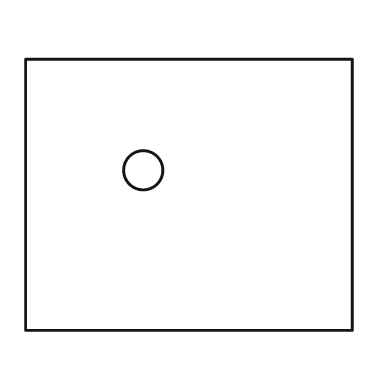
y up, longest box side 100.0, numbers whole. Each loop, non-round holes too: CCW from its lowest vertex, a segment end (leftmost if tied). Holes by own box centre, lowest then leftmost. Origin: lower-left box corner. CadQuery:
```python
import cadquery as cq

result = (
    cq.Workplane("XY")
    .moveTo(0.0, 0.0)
    .lineTo(100.0, 0.0)
    .lineTo(100.0, 83.0)
    .lineTo(0.0, 83.0)
    .close()
    .moveTo(36.0, 49.0)
    .circle(6.0)
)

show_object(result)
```